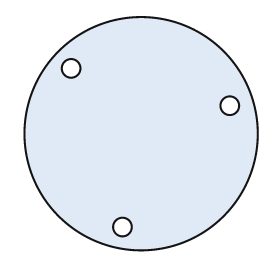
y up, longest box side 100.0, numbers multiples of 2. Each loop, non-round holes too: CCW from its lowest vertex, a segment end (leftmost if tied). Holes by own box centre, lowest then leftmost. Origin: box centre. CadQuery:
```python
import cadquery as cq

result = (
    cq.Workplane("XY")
    .moveTo(0.0, 0.0)
    .circle(50.0)
    .moveTo(-8.0, -40.0)
    .circle(4.0)
    .moveTo(38.0, 12.0)
    .circle(4.0)
    .moveTo(-30.0, 28.0)
    .circle(4.0)
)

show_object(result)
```